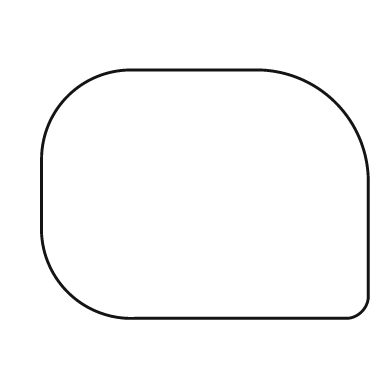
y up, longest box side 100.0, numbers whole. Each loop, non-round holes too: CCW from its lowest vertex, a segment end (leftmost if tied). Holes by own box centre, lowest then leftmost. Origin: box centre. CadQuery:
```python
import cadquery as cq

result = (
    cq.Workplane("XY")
    .moveTo(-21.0, -38.0)
    .lineTo(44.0, -38.0)
    .threePointArc((48.0, -36.0), (50.0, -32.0))
    .lineTo(50.0, 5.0)
    .threePointArc((40.0, 28.0), (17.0, 38.0))
    .lineTo(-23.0, 38.0)
    .threePointArc((-42.0, 30.0), (-50.0, 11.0))
    .lineTo(-50.0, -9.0)
    .threePointArc((-42.0, -30.0), (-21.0, -38.0))
    .close()
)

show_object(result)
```